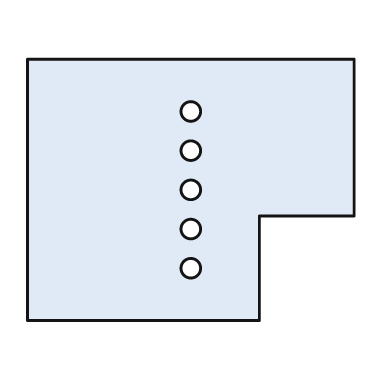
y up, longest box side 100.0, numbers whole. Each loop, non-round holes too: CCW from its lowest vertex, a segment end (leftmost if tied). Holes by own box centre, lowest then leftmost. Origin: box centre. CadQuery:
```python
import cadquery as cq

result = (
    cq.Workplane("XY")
    .moveTo(-50.0, -40.0)
    .lineTo(21.0, -40.0)
    .lineTo(21.0, -8.0)
    .lineTo(50.0, -8.0)
    .lineTo(50.0, 40.0)
    .lineTo(-50.0, 40.0)
    .close()
    .moveTo(0.0, -24.0)
    .circle(3.0)
    .moveTo(0.0, -12.0)
    .circle(3.0)
    .moveTo(0.0, 0.0)
    .circle(3.0)
    .moveTo(0.0, 12.0)
    .circle(3.0)
    .moveTo(0.0, 24.0)
    .circle(3.0)
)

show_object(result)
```